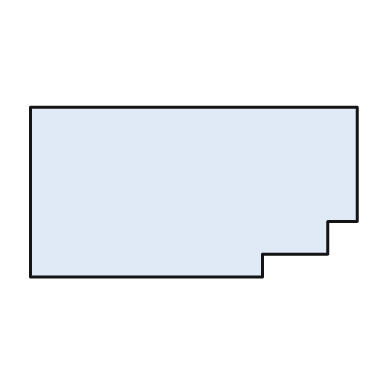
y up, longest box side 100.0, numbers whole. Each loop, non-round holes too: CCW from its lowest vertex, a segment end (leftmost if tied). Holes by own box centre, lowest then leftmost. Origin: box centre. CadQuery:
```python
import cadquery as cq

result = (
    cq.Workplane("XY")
    .moveTo(-50.0, -26.0)
    .lineTo(21.0, -26.0)
    .lineTo(21.0, -19.0)
    .lineTo(41.0, -19.0)
    .lineTo(41.0, -9.0)
    .lineTo(50.0, -9.0)
    .lineTo(50.0, 26.0)
    .lineTo(-50.0, 26.0)
    .close()
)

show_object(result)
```